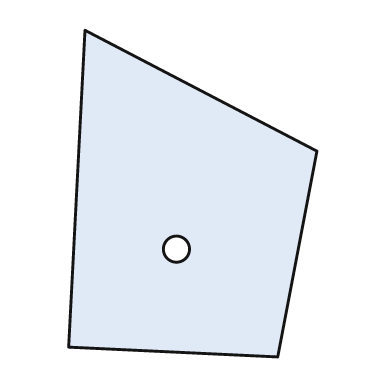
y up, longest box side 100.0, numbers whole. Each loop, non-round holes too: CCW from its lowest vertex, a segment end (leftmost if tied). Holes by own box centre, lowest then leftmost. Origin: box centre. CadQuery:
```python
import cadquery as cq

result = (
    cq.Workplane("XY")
    .moveTo(26.0, -50.0)
    .lineTo(38.0, 13.0)
    .lineTo(-33.0, 50.0)
    .lineTo(-38.0, -47.0)
    .close()
    .moveTo(-5.0, -17.0)
    .circle(4.0)
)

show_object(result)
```